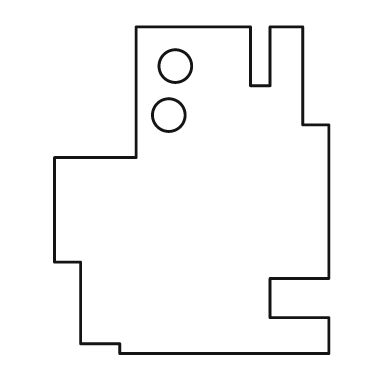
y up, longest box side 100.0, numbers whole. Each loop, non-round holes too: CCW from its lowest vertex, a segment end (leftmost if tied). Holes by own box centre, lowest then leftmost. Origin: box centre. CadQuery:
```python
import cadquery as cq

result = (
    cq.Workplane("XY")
    .moveTo(-22.0, -50.0)
    .lineTo(42.0, -50.0)
    .lineTo(42.0, -39.0)
    .lineTo(24.0, -39.0)
    .lineTo(24.0, -27.0)
    .lineTo(42.0, -27.0)
    .lineTo(42.0, 20.0)
    .lineTo(34.0, 20.0)
    .lineTo(34.0, 50.0)
    .lineTo(24.0, 50.0)
    .lineTo(24.0, 32.0)
    .lineTo(18.0, 32.0)
    .lineTo(18.0, 50.0)
    .lineTo(-17.0, 50.0)
    .lineTo(-17.0, 10.0)
    .lineTo(-42.0, 10.0)
    .lineTo(-42.0, -22.0)
    .lineTo(-34.0, -22.0)
    .lineTo(-34.0, -47.0)
    .lineTo(-22.0, -47.0)
    .close()
    .moveTo(-7.0, 23.0)
    .circle(5.0)
    .moveTo(-5.0, 38.0)
    .circle(5.0)
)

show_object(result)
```